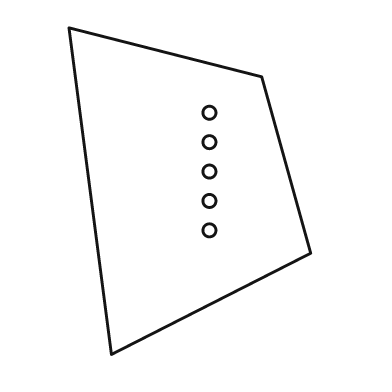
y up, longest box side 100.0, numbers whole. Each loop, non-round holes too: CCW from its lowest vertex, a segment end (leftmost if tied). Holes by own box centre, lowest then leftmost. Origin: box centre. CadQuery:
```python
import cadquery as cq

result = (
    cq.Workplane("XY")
    .moveTo(-24.0, -50.0)
    .lineTo(37.0, -19.0)
    .lineTo(22.0, 35.0)
    .lineTo(-37.0, 50.0)
    .close()
    .moveTo(6.0, -12.0)
    .circle(2.0)
    .moveTo(6.0, -3.0)
    .circle(2.0)
    .moveTo(6.0, 6.0)
    .circle(2.0)
    .moveTo(6.0, 15.0)
    .circle(2.0)
    .moveTo(6.0, 24.0)
    .circle(2.0)
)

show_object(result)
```